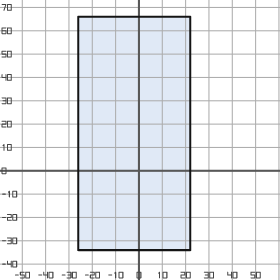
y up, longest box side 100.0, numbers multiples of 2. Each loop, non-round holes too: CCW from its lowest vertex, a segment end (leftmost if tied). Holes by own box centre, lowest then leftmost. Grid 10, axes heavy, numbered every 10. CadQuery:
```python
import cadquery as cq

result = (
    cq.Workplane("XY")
    .moveTo(-26.0, -34.0)
    .lineTo(22.0, -34.0)
    .lineTo(22.0, 66.0)
    .lineTo(-26.0, 66.0)
    .close()
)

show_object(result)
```